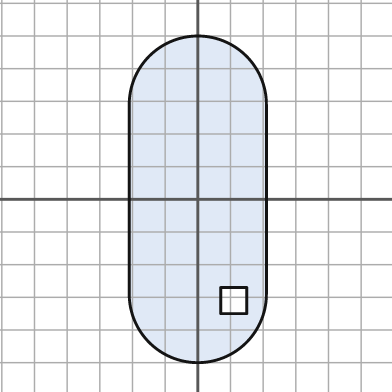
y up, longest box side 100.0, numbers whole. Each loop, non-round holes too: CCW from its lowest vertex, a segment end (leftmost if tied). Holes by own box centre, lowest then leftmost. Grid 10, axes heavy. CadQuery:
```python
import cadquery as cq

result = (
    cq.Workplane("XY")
    .moveTo(-21.0, -29.0)
    .threePointArc((0.0, -50.0), (21.0, -29.0))
    .lineTo(21.0, 29.0)
    .threePointArc((0.0, 50.0), (-21.0, 29.0))
    .close()
    .moveTo(7.0, -35.0)
    .lineTo(15.0, -35.0)
    .lineTo(15.0, -27.0)
    .lineTo(7.0, -27.0)
    .close()
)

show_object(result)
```